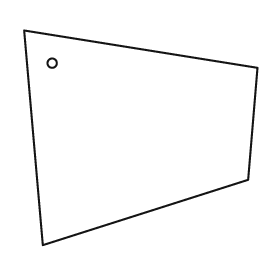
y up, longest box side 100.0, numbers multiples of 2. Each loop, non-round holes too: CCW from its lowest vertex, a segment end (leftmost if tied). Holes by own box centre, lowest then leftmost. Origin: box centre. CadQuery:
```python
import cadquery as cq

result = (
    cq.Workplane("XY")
    .moveTo(-42.0, -46.0)
    .lineTo(46.0, -18.0)
    .lineTo(50.0, 30.0)
    .lineTo(-50.0, 46.0)
    .close()
    .moveTo(-38.0, 32.0)
    .circle(2.0)
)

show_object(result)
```